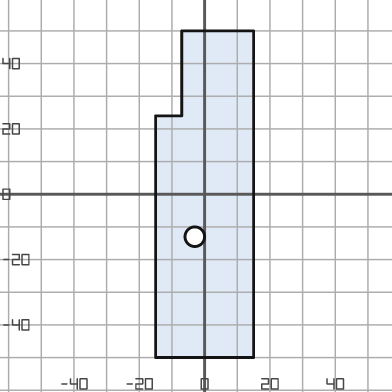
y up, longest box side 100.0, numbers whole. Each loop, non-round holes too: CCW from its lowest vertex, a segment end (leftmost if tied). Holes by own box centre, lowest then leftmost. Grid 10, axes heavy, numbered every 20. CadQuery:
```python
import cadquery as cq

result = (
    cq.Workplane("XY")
    .moveTo(-15.0, -50.0)
    .lineTo(15.0, -50.0)
    .lineTo(15.0, 50.0)
    .lineTo(-7.0, 50.0)
    .lineTo(-7.0, 24.0)
    .lineTo(-15.0, 24.0)
    .close()
    .moveTo(-3.0, -13.0)
    .circle(3.0)
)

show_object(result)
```